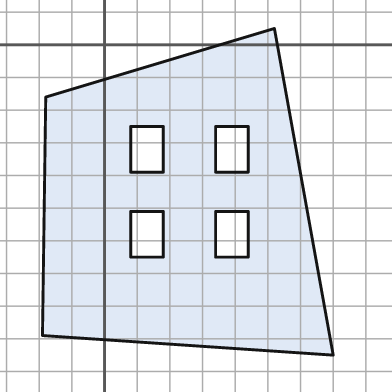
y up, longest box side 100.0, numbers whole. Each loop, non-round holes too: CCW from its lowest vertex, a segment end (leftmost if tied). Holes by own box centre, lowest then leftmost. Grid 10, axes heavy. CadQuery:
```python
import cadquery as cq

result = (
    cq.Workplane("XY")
    .moveTo(70.0, -95.0)
    .lineTo(52.0, 5.0)
    .lineTo(-18.0, -16.0)
    .lineTo(-19.0, -89.0)
    .close()
    .moveTo(8.0, -65.0)
    .lineTo(18.0, -65.0)
    .lineTo(18.0, -51.0)
    .lineTo(8.0, -51.0)
    .close()
    .moveTo(34.0, -65.0)
    .lineTo(44.0, -65.0)
    .lineTo(44.0, -51.0)
    .lineTo(34.0, -51.0)
    .close()
    .moveTo(8.0, -39.0)
    .lineTo(18.0, -39.0)
    .lineTo(18.0, -25.0)
    .lineTo(8.0, -25.0)
    .close()
    .moveTo(34.0, -39.0)
    .lineTo(44.0, -39.0)
    .lineTo(44.0, -25.0)
    .lineTo(34.0, -25.0)
    .close()
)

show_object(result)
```